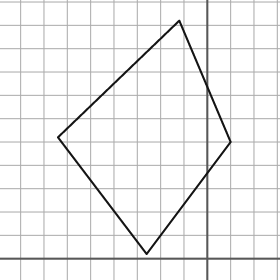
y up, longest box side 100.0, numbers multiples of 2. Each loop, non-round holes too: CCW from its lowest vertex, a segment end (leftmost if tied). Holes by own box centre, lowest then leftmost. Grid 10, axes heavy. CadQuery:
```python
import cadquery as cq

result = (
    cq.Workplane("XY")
    .moveTo(-26.0, 2.0)
    .lineTo(10.0, 50.0)
    .lineTo(-12.0, 102.0)
    .lineTo(-64.0, 52.0)
    .close()
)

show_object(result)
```